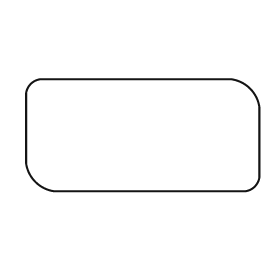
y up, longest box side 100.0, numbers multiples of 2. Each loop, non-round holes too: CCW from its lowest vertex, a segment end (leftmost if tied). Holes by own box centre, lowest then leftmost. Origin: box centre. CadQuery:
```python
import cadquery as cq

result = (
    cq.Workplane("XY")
    .moveTo(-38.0, -24.0)
    .lineTo(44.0, -24.0)
    .threePointArc((48.0, -22.0), (50.0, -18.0))
    .lineTo(50.0, 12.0)
    .threePointArc((46.0, 20.0), (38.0, 24.0))
    .lineTo(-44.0, 24.0)
    .threePointArc((-48.0, 22.0), (-50.0, 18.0))
    .lineTo(-50.0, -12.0)
    .threePointArc((-46.0, -20.0), (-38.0, -24.0))
    .close()
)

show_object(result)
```